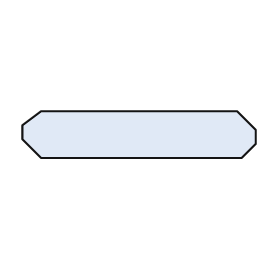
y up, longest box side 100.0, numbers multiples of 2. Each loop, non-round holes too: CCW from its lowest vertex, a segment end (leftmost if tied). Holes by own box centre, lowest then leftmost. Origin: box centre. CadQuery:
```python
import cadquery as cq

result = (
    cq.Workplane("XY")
    .moveTo(-42.0, -10.0)
    .lineTo(44.0, -10.0)
    .lineTo(50.0, -4.0)
    .lineTo(50.0, 2.0)
    .lineTo(42.0, 10.0)
    .lineTo(-42.0, 10.0)
    .lineTo(-50.0, 4.0)
    .lineTo(-50.0, -2.0)
    .close()
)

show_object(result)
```